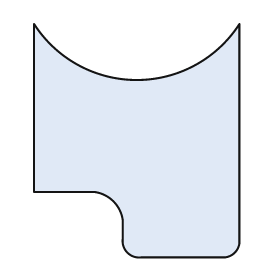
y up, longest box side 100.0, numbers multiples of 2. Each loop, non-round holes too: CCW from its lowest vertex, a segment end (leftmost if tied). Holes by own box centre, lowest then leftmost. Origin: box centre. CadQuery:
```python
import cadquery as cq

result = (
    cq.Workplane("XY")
    .moveTo(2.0, -50.0)
    .lineTo(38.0, -50.0)
    .threePointArc((42.0, -48.0), (44.0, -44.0))
    .lineTo(44.0, 50.0)
    .threePointArc((0.0, 26.0), (-44.0, 50.0))
    .lineTo(-44.0, -22.0)
    .lineTo(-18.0, -22.0)
    .threePointArc((-10.0, -26.0), (-6.0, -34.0))
    .lineTo(-6.0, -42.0)
    .threePointArc((-4.0, -48.0), (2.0, -50.0))
    .close()
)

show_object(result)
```